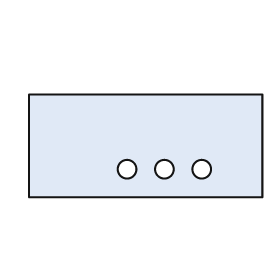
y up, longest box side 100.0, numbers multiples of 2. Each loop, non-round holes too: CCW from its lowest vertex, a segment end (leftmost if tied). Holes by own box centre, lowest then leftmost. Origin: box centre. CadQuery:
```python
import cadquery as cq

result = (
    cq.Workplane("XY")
    .moveTo(-50.0, -22.0)
    .lineTo(50.0, -22.0)
    .lineTo(50.0, 22.0)
    .lineTo(-50.0, 22.0)
    .close()
    .moveTo(-8.0, -10.0)
    .circle(4.0)
    .moveTo(8.0, -10.0)
    .circle(4.0)
    .moveTo(24.0, -10.0)
    .circle(4.0)
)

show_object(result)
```